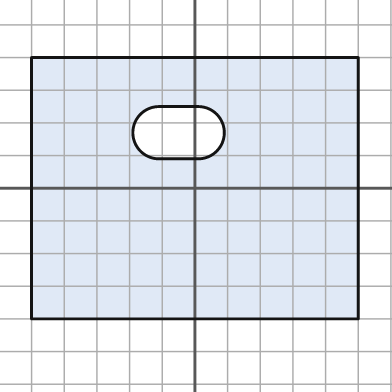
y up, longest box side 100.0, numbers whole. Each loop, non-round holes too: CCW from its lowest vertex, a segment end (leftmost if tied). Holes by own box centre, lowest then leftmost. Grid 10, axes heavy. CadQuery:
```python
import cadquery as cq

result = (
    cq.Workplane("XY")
    .moveTo(-50.0, -40.0)
    .lineTo(50.0, -40.0)
    .lineTo(50.0, 40.0)
    .lineTo(-50.0, 40.0)
    .close()
    .moveTo(-11.0, 9.0)
    .lineTo(1.0, 9.0)
    .threePointArc((9.0, 17.0), (1.0, 25.0))
    .lineTo(-11.0, 25.0)
    .threePointArc((-19.0, 17.0), (-11.0, 9.0))
    .close()
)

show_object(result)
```